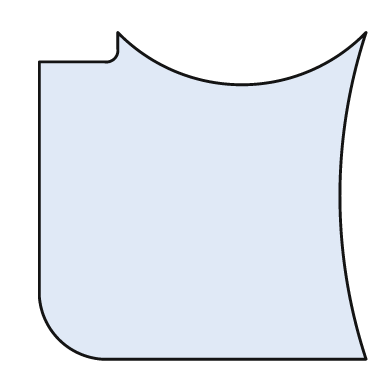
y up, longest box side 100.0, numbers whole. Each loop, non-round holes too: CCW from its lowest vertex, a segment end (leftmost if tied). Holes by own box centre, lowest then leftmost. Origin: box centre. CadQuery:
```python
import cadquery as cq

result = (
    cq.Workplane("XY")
    .moveTo(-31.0, -50.0)
    .lineTo(50.0, -50.0)
    .threePointArc((42.0, 0.0), (50.0, 50.0))
    .threePointArc((12.0, 34.0), (-26.0, 50.0))
    .lineTo(-26.0, 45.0)
    .threePointArc((-27.0, 42.0), (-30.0, 41.0))
    .lineTo(-50.0, 41.0)
    .lineTo(-50.0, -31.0)
    .threePointArc((-44.0, -44.0), (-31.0, -50.0))
    .close()
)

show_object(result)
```